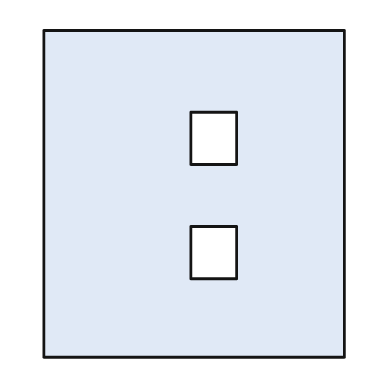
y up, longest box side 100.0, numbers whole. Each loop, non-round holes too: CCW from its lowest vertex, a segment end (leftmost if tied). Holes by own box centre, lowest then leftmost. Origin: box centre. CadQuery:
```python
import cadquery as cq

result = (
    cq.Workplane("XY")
    .moveTo(-46.0, -50.0)
    .lineTo(46.0, -50.0)
    .lineTo(46.0, 50.0)
    .lineTo(-46.0, 50.0)
    .close()
    .moveTo(-1.0, -26.0)
    .lineTo(13.0, -26.0)
    .lineTo(13.0, -10.0)
    .lineTo(-1.0, -10.0)
    .close()
    .moveTo(-1.0, 9.0)
    .lineTo(13.0, 9.0)
    .lineTo(13.0, 25.0)
    .lineTo(-1.0, 25.0)
    .close()
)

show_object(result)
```